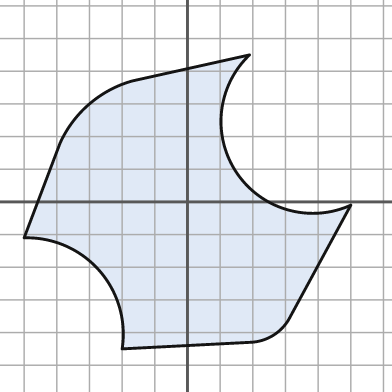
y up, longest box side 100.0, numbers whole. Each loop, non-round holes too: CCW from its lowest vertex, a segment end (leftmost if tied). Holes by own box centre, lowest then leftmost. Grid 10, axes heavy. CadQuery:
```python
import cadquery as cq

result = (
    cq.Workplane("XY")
    .moveTo(-20.0, -45.0)
    .lineTo(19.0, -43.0)
    .threePointArc((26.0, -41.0), (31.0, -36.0))
    .lineTo(50.0, -1.0)
    .threePointArc((15.0, 9.0), (19.0, 45.0))
    .lineTo(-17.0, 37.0)
    .threePointArc((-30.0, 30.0), (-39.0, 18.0))
    .lineTo(-50.0, -11.0)
    .threePointArc((-27.0, -21.0), (-20.0, -45.0))
    .close()
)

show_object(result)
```